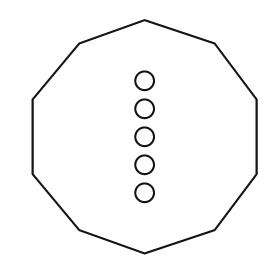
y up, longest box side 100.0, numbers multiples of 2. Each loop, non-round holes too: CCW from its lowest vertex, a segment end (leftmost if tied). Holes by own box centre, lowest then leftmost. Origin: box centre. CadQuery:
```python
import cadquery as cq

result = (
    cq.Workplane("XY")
    .moveTo(0.0, -50.0)
    .lineTo(30.0, -40.0)
    .lineTo(48.0, -16.0)
    .lineTo(48.0, 16.0)
    .lineTo(30.0, 40.0)
    .lineTo(0.0, 50.0)
    .lineTo(-28.0, 40.0)
    .lineTo(-48.0, 16.0)
    .lineTo(-48.0, -16.0)
    .lineTo(-28.0, -40.0)
    .close()
    .moveTo(0.0, -24.0)
    .circle(4.0)
    .moveTo(0.0, -12.0)
    .circle(4.0)
    .moveTo(0.0, 0.0)
    .circle(4.0)
    .moveTo(0.0, 12.0)
    .circle(4.0)
    .moveTo(0.0, 24.0)
    .circle(4.0)
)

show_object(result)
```